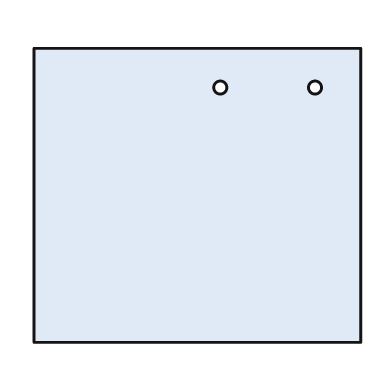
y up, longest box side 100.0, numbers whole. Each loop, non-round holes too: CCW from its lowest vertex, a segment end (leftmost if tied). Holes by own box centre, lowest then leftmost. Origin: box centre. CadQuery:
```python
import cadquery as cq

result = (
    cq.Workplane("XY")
    .moveTo(-50.0, -45.0)
    .lineTo(50.0, -45.0)
    .lineTo(50.0, 45.0)
    .lineTo(-50.0, 45.0)
    .close()
    .moveTo(7.0, 33.0)
    .circle(2.0)
    .moveTo(36.0, 33.0)
    .circle(2.0)
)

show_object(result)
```